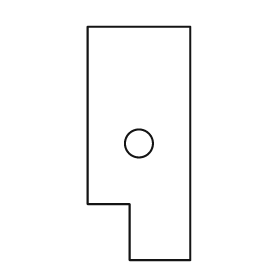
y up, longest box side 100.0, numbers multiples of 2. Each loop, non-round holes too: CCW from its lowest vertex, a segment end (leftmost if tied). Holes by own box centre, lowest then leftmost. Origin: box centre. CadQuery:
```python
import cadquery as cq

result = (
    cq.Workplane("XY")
    .moveTo(-4.0, -50.0)
    .lineTo(22.0, -50.0)
    .lineTo(22.0, 50.0)
    .lineTo(-22.0, 50.0)
    .lineTo(-22.0, -26.0)
    .lineTo(-4.0, -26.0)
    .close()
    .moveTo(0.0, 0.0)
    .circle(6.0)
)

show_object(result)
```